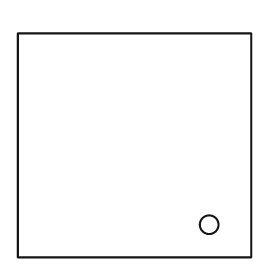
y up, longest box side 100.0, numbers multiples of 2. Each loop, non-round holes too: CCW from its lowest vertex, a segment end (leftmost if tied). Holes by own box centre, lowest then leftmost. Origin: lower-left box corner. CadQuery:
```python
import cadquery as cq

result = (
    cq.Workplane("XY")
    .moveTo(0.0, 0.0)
    .lineTo(100.0, 0.0)
    .lineTo(100.0, 96.0)
    .lineTo(0.0, 96.0)
    .close()
    .moveTo(82.0, 14.0)
    .circle(4.0)
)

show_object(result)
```